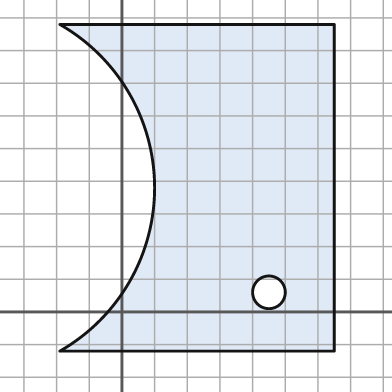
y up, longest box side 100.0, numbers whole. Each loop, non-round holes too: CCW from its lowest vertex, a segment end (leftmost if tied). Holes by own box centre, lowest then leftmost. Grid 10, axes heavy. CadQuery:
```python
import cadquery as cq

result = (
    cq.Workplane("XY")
    .moveTo(-19.0, -12.0)
    .lineTo(65.0, -12.0)
    .lineTo(65.0, 88.0)
    .lineTo(-19.0, 88.0)
    .threePointArc((10.0, 38.0), (-19.0, -12.0))
    .close()
    .moveTo(45.0, 6.0)
    .circle(5.0)
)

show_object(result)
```